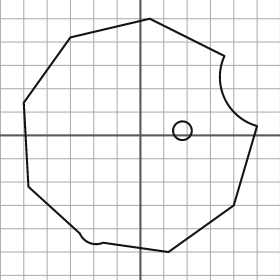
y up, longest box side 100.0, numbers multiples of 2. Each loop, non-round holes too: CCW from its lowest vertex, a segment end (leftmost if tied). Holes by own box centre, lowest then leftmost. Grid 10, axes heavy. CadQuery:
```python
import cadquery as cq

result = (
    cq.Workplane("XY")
    .moveTo(12.0, -50.0)
    .lineTo(40.0, -30.0)
    .lineTo(50.0, 4.0)
    .threePointArc((36.0, 16.0), (36.0, 34.0))
    .lineTo(4.0, 50.0)
    .lineTo(-30.0, 42.0)
    .lineTo(-50.0, 14.0)
    .lineTo(-48.0, -22.0)
    .lineTo(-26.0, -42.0)
    .threePointArc((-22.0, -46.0), (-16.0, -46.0))
    .close()
    .moveTo(18.0, 2.0)
    .circle(4.0)
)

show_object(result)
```